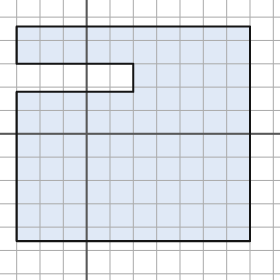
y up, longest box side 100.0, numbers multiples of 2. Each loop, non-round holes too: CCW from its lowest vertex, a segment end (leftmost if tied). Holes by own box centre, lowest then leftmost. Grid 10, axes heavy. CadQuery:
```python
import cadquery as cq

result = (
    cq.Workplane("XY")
    .moveTo(-30.0, -46.0)
    .lineTo(70.0, -46.0)
    .lineTo(70.0, 46.0)
    .lineTo(-30.0, 46.0)
    .lineTo(-30.0, 30.0)
    .lineTo(20.0, 30.0)
    .lineTo(20.0, 18.0)
    .lineTo(-30.0, 18.0)
    .close()
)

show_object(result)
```